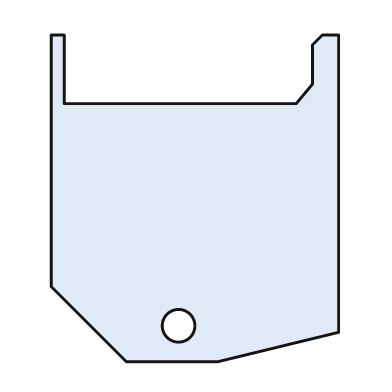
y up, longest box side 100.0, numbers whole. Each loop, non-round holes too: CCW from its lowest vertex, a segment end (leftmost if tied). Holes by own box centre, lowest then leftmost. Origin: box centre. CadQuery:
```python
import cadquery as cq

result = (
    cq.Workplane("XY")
    .moveTo(-21.0, -50.0)
    .lineTo(7.0, -50.0)
    .lineTo(44.0, -41.0)
    .lineTo(44.0, 50.0)
    .lineTo(39.0, 50.0)
    .lineTo(36.0, 47.0)
    .lineTo(36.0, 35.0)
    .lineTo(31.0, 29.0)
    .lineTo(-40.0, 29.0)
    .lineTo(-40.0, 50.0)
    .lineTo(-44.0, 50.0)
    .lineTo(-44.0, -27.0)
    .close()
    .moveTo(-5.0, -39.0)
    .circle(5.0)
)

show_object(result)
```